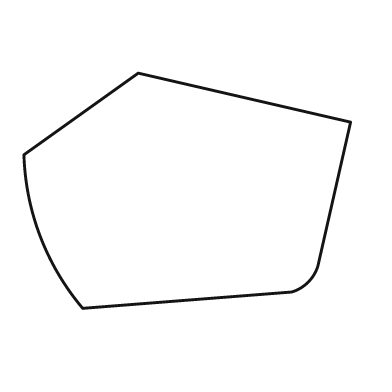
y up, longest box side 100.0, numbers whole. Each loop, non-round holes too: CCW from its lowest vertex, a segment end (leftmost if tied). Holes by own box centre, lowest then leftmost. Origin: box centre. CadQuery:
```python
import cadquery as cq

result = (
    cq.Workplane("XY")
    .moveTo(-32.0, -36.0)
    .lineTo(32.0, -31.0)
    .threePointArc((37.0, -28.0), (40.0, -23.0))
    .lineTo(50.0, 21.0)
    .lineTo(-15.0, 36.0)
    .lineTo(-50.0, 11.0)
    .threePointArc((-45.0, -14.0), (-32.0, -36.0))
    .close()
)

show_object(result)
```